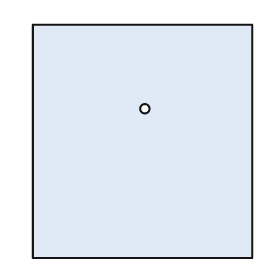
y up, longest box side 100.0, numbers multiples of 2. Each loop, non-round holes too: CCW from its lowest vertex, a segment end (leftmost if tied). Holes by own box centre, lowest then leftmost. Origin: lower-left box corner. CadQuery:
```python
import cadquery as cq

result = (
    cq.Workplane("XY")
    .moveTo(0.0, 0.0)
    .lineTo(94.0, 0.0)
    .lineTo(94.0, 100.0)
    .lineTo(0.0, 100.0)
    .close()
    .moveTo(48.0, 64.0)
    .circle(2.0)
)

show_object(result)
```